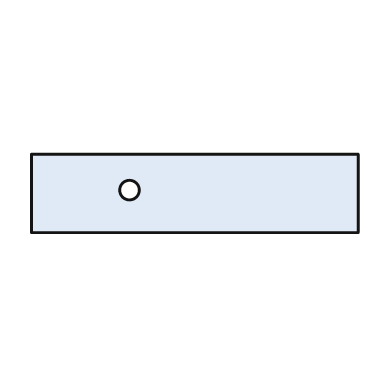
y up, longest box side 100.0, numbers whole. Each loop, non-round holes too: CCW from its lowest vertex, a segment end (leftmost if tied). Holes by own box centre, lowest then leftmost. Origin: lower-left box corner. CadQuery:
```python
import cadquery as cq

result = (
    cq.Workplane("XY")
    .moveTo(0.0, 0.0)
    .lineTo(100.0, 0.0)
    .lineTo(100.0, 24.0)
    .lineTo(0.0, 24.0)
    .close()
    .moveTo(30.0, 13.0)
    .circle(3.0)
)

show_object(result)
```